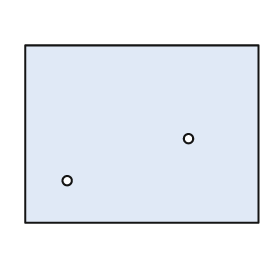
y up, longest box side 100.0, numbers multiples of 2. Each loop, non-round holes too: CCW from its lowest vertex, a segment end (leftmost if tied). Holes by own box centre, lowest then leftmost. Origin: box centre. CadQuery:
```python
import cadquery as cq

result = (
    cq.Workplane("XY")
    .moveTo(-50.0, -38.0)
    .lineTo(50.0, -38.0)
    .lineTo(50.0, 38.0)
    .lineTo(-50.0, 38.0)
    .close()
    .moveTo(-32.0, -20.0)
    .circle(2.0)
    .moveTo(20.0, -2.0)
    .circle(2.0)
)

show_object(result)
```